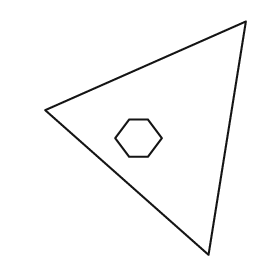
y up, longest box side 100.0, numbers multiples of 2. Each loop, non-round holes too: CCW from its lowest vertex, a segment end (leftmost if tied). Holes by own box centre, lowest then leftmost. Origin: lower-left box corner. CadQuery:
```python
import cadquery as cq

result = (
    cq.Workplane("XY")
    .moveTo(70.0, 0.0)
    .lineTo(86.0, 100.0)
    .lineTo(0.0, 62.0)
    .close()
    .moveTo(36.0, 42.0)
    .lineTo(44.0, 42.0)
    .lineTo(50.0, 50.0)
    .lineTo(44.0, 58.0)
    .lineTo(36.0, 58.0)
    .lineTo(30.0, 50.0)
    .close()
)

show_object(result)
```